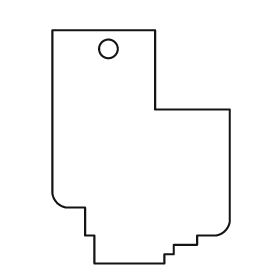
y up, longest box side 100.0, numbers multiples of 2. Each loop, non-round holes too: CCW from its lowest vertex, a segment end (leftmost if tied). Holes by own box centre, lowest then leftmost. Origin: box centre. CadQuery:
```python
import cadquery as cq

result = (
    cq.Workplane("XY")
    .moveTo(-20.0, -50.0)
    .lineTo(10.0, -50.0)
    .lineTo(10.0, -46.0)
    .lineTo(14.0, -46.0)
    .lineTo(14.0, -42.0)
    .lineTo(24.0, -42.0)
    .lineTo(24.0, -38.0)
    .lineTo(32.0, -38.0)
    .threePointArc((36.0, -36.0), (38.0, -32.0))
    .lineTo(38.0, 16.0)
    .lineTo(6.0, 16.0)
    .lineTo(6.0, 50.0)
    .lineTo(-38.0, 50.0)
    .lineTo(-38.0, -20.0)
    .threePointArc((-36.0, -24.0), (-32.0, -26.0))
    .lineTo(-24.0, -26.0)
    .lineTo(-24.0, -38.0)
    .lineTo(-20.0, -38.0)
    .close()
    .moveTo(-14.0, 42.0)
    .circle(4.0)
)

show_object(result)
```